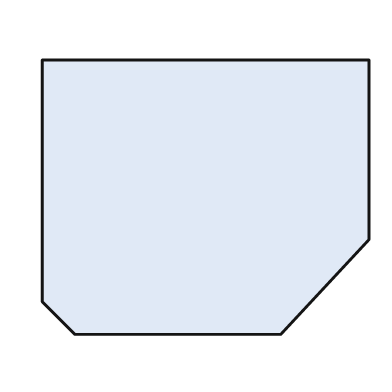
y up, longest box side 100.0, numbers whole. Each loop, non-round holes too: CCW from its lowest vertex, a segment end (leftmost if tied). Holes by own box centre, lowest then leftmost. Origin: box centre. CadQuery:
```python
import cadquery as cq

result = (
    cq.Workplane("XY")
    .moveTo(-40.0, -42.0)
    .lineTo(23.0, -42.0)
    .lineTo(50.0, -13.0)
    .lineTo(50.0, 42.0)
    .lineTo(-50.0, 42.0)
    .lineTo(-50.0, -32.0)
    .close()
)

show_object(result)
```